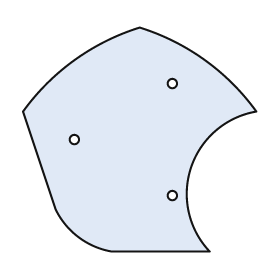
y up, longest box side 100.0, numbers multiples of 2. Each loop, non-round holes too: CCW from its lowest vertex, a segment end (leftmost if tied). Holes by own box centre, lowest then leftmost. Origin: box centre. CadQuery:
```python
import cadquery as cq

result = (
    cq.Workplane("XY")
    .moveTo(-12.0, -48.0)
    .lineTo(30.0, -48.0)
    .threePointArc((22.0, -12.0), (50.0, 12.0))
    .threePointArc((28.0, 34.0), (0.0, 48.0))
    .threePointArc((-28.0, 34.0), (-50.0, 12.0))
    .lineTo(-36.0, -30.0)
    .threePointArc((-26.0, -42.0), (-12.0, -48.0))
    .close()
    .moveTo(14.0, -24.0)
    .circle(2.0)
    .moveTo(-28.0, 0.0)
    .circle(2.0)
    .moveTo(14.0, 24.0)
    .circle(2.0)
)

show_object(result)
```